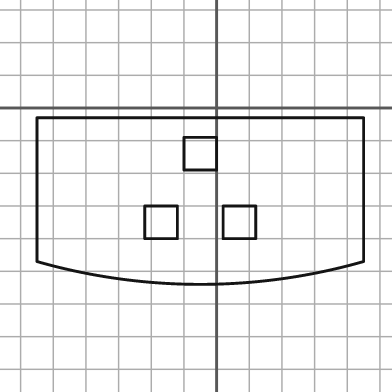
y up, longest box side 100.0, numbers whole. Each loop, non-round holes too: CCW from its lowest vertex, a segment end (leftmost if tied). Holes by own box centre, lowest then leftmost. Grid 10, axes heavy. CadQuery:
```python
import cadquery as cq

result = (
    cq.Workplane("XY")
    .moveTo(-55.0, -47.0)
    .threePointArc((-5.0, -54.0), (45.0, -47.0))
    .lineTo(45.0, -3.0)
    .lineTo(-55.0, -3.0)
    .close()
    .moveTo(-22.0, -40.0)
    .lineTo(-12.0, -40.0)
    .lineTo(-12.0, -30.0)
    .lineTo(-22.0, -30.0)
    .close()
    .moveTo(2.0, -40.0)
    .lineTo(12.0, -40.0)
    .lineTo(12.0, -30.0)
    .lineTo(2.0, -30.0)
    .close()
    .moveTo(-10.0, -19.0)
    .lineTo(0.0, -19.0)
    .lineTo(0.0, -9.0)
    .lineTo(-10.0, -9.0)
    .close()
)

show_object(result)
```